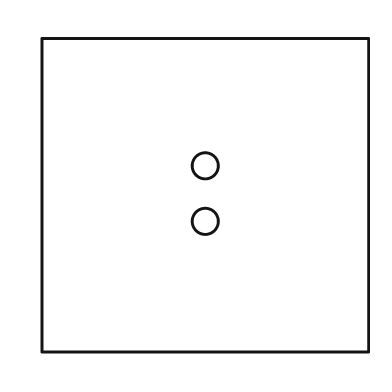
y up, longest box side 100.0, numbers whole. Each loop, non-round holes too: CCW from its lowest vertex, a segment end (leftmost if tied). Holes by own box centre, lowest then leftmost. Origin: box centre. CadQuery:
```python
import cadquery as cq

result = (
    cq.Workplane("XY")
    .moveTo(-50.0, -48.0)
    .lineTo(50.0, -48.0)
    .lineTo(50.0, 48.0)
    .lineTo(-50.0, 48.0)
    .close()
    .moveTo(0.0, -8.0)
    .circle(4.0)
    .moveTo(0.0, 9.0)
    .circle(4.0)
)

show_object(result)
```